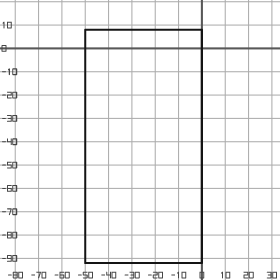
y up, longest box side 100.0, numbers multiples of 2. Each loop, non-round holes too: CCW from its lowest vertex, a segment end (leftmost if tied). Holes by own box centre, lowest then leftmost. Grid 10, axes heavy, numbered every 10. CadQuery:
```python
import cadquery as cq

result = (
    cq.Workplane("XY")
    .moveTo(-50.0, -92.0)
    .lineTo(0.0, -92.0)
    .lineTo(0.0, 8.0)
    .lineTo(-50.0, 8.0)
    .close()
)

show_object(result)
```